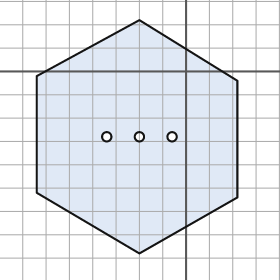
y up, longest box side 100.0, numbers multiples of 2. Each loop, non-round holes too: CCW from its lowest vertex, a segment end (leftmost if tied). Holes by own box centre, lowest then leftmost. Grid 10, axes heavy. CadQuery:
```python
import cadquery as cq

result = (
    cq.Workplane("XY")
    .moveTo(-20.0, -78.0)
    .lineTo(22.0, -54.0)
    .lineTo(22.0, -4.0)
    .lineTo(-20.0, 22.0)
    .lineTo(-64.0, -2.0)
    .lineTo(-64.0, -52.0)
    .close()
    .moveTo(-34.0, -28.0)
    .circle(2.0)
    .moveTo(-20.0, -28.0)
    .circle(2.0)
    .moveTo(-6.0, -28.0)
    .circle(2.0)
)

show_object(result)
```